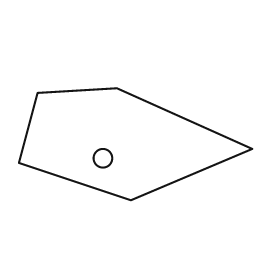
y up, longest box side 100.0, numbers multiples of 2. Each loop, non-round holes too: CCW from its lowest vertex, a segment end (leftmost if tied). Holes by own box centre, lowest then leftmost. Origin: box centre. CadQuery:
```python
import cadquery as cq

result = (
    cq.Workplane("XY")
    .moveTo(-2.0, -24.0)
    .lineTo(50.0, -2.0)
    .lineTo(-8.0, 24.0)
    .lineTo(-42.0, 22.0)
    .lineTo(-50.0, -8.0)
    .close()
    .moveTo(-14.0, -6.0)
    .circle(4.0)
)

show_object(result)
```